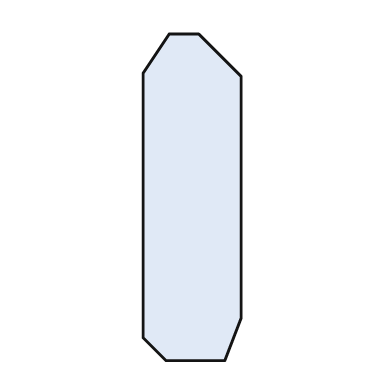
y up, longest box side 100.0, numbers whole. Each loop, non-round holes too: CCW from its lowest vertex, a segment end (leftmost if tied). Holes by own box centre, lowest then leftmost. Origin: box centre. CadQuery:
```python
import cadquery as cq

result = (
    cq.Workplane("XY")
    .moveTo(-8.0, -50.0)
    .lineTo(10.0, -50.0)
    .lineTo(15.0, -37.0)
    .lineTo(15.0, 37.0)
    .lineTo(2.0, 50.0)
    .lineTo(-7.0, 50.0)
    .lineTo(-15.0, 38.0)
    .lineTo(-15.0, -43.0)
    .close()
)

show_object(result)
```